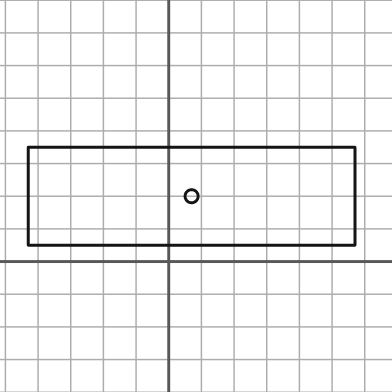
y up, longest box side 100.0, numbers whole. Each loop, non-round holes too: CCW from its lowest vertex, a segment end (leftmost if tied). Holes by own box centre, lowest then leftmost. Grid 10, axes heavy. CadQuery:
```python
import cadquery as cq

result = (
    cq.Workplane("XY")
    .moveTo(-43.0, 5.0)
    .lineTo(57.0, 5.0)
    .lineTo(57.0, 35.0)
    .lineTo(-43.0, 35.0)
    .close()
    .moveTo(7.0, 20.0)
    .circle(2.0)
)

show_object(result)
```